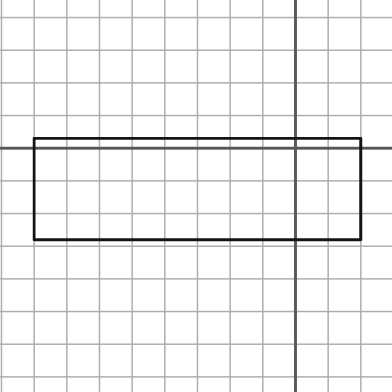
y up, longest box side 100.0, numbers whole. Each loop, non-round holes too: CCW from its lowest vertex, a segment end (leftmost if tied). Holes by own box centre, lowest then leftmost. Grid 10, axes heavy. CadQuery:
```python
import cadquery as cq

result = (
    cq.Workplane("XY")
    .moveTo(-80.0, -28.0)
    .lineTo(20.0, -28.0)
    .lineTo(20.0, 3.0)
    .lineTo(-80.0, 3.0)
    .close()
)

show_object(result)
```